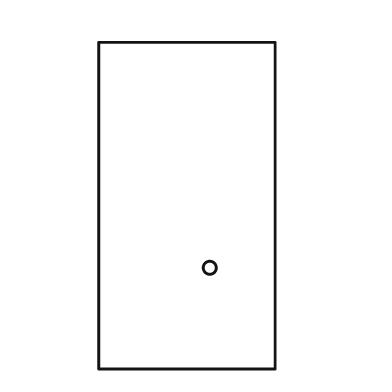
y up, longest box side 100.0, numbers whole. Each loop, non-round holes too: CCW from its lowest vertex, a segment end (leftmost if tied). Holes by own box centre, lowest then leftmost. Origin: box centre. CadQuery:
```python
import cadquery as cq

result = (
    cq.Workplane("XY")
    .moveTo(-27.0, -50.0)
    .lineTo(27.0, -50.0)
    .lineTo(27.0, 50.0)
    .lineTo(-27.0, 50.0)
    .close()
    .moveTo(7.0, -19.0)
    .circle(2.0)
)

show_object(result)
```